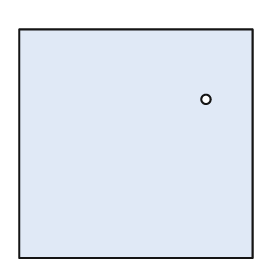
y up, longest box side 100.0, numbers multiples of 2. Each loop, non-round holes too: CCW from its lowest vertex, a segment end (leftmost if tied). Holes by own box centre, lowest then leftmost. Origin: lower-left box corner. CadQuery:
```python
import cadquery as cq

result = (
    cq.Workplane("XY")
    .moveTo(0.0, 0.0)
    .lineTo(100.0, 0.0)
    .lineTo(100.0, 98.0)
    .lineTo(0.0, 98.0)
    .close()
    .moveTo(80.0, 68.0)
    .circle(2.0)
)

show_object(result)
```